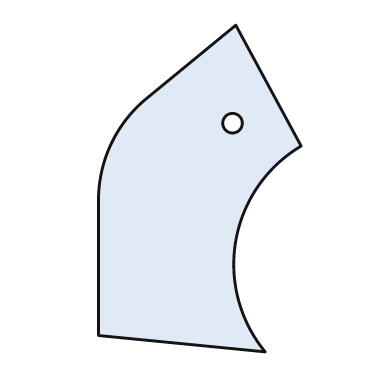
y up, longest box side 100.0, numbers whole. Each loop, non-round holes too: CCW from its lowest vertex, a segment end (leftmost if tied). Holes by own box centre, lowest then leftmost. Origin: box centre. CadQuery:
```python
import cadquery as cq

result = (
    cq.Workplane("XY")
    .moveTo(20.0, -50.0)
    .threePointArc((11.0, -16.0), (31.0, 13.0))
    .lineTo(11.0, 50.0)
    .lineTo(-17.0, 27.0)
    .threePointArc((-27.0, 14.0), (-31.0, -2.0))
    .lineTo(-31.0, -45.0)
    .close()
    .moveTo(10.0, 20.0)
    .circle(3.0)
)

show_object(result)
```